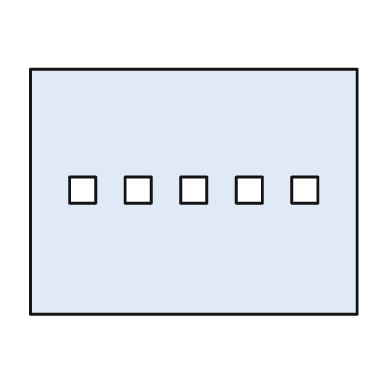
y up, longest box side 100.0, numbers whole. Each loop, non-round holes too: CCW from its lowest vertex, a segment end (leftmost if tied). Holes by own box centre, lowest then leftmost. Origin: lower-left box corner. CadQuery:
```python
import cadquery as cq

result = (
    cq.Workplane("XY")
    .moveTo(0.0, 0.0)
    .lineTo(100.0, 0.0)
    .lineTo(100.0, 75.0)
    .lineTo(0.0, 75.0)
    .close()
    .moveTo(12.0, 34.0)
    .lineTo(20.0, 34.0)
    .lineTo(20.0, 42.0)
    .lineTo(12.0, 42.0)
    .close()
    .moveTo(29.0, 34.0)
    .lineTo(37.0, 34.0)
    .lineTo(37.0, 42.0)
    .lineTo(29.0, 42.0)
    .close()
    .moveTo(46.0, 34.0)
    .lineTo(54.0, 34.0)
    .lineTo(54.0, 42.0)
    .lineTo(46.0, 42.0)
    .close()
    .moveTo(63.0, 34.0)
    .lineTo(71.0, 34.0)
    .lineTo(71.0, 42.0)
    .lineTo(63.0, 42.0)
    .close()
    .moveTo(80.0, 34.0)
    .lineTo(88.0, 34.0)
    .lineTo(88.0, 42.0)
    .lineTo(80.0, 42.0)
    .close()
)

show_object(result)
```